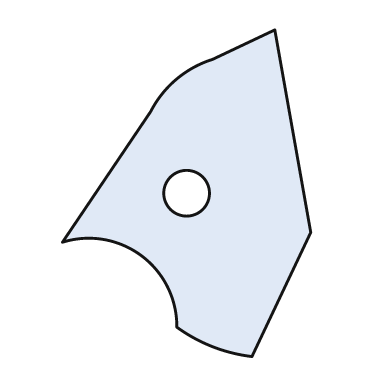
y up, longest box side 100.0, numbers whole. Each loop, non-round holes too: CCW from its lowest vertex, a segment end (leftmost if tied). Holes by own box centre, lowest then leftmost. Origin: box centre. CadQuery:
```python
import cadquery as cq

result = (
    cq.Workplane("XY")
    .moveTo(20.0, -50.0)
    .lineTo(38.0, -12.0)
    .lineTo(27.0, 50.0)
    .lineTo(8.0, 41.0)
    .threePointArc((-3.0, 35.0), (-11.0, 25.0))
    .lineTo(-38.0, -15.0)
    .threePointArc((-14.0, -19.0), (-3.0, -41.0))
    .threePointArc((8.0, -47.0), (20.0, -50.0))
    .close()
    .moveTo(0.0, 0.0)
    .circle(7.0)
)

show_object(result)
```